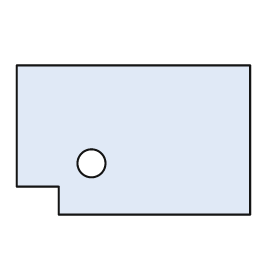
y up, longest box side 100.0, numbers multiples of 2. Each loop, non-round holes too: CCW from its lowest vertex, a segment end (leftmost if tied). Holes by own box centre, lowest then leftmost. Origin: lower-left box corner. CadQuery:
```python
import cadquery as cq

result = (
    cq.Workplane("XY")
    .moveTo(18.0, 0.0)
    .lineTo(100.0, 0.0)
    .lineTo(100.0, 64.0)
    .lineTo(0.0, 64.0)
    .lineTo(0.0, 12.0)
    .lineTo(18.0, 12.0)
    .close()
    .moveTo(32.0, 22.0)
    .circle(6.0)
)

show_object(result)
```